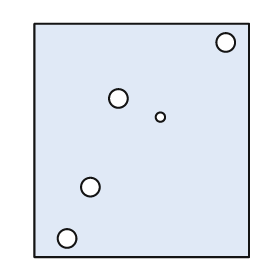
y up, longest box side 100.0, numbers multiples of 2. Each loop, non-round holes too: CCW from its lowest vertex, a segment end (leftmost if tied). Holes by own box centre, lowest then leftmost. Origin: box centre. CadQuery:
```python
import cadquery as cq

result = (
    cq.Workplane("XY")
    .moveTo(-46.0, -50.0)
    .lineTo(46.0, -50.0)
    .lineTo(46.0, 50.0)
    .lineTo(-46.0, 50.0)
    .close()
    .moveTo(-32.0, -42.0)
    .circle(4.0)
    .moveTo(-22.0, -20.0)
    .circle(4.0)
    .moveTo(8.0, 10.0)
    .circle(2.0)
    .moveTo(-10.0, 18.0)
    .circle(4.0)
    .moveTo(36.0, 42.0)
    .circle(4.0)
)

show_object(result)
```